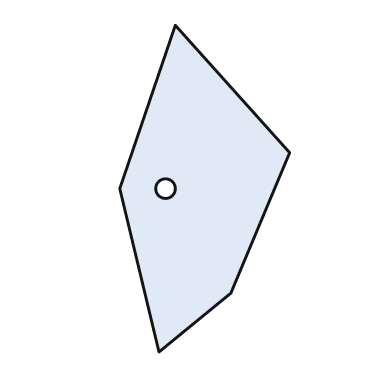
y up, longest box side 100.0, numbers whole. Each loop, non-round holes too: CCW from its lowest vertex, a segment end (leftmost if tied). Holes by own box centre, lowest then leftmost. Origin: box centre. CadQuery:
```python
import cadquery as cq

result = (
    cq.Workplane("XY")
    .moveTo(-14.0, -50.0)
    .lineTo(8.0, -32.0)
    .lineTo(26.0, 11.0)
    .lineTo(-9.0, 50.0)
    .lineTo(-26.0, 0.0)
    .close()
    .moveTo(-12.0, 0.0)
    .circle(3.0)
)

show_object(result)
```